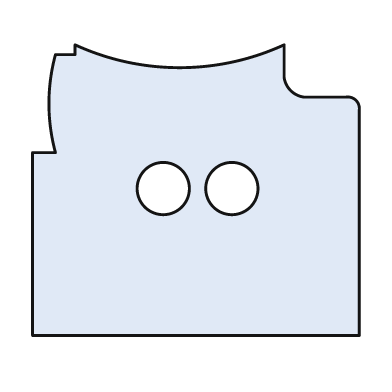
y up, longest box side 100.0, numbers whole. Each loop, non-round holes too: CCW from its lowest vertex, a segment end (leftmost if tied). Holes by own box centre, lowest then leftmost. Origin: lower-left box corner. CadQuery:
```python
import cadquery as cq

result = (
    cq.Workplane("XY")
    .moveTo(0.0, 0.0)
    .lineTo(100.0, 0.0)
    .lineTo(100.0, 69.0)
    .threePointArc((99.0, 72.0), (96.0, 73.0))
    .lineTo(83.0, 73.0)
    .threePointArc((79.0, 75.0), (77.0, 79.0))
    .lineTo(77.0, 89.0)
    .threePointArc((45.0, 82.0), (13.0, 89.0))
    .lineTo(13.0, 86.0)
    .lineTo(7.0, 86.0)
    .threePointArc((5.0, 71.0), (7.0, 56.0))
    .lineTo(0.0, 56.0)
    .close()
    .moveTo(40.0, 45.0)
    .circle(8.0)
    .moveTo(61.0, 45.0)
    .circle(8.0)
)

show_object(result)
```